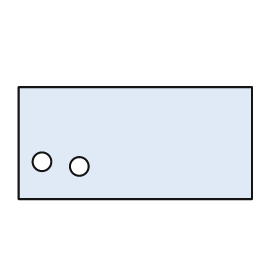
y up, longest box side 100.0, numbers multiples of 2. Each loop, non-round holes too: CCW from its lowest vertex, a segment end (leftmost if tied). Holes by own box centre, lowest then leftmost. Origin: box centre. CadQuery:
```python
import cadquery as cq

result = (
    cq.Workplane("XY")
    .moveTo(-50.0, -24.0)
    .lineTo(50.0, -24.0)
    .lineTo(50.0, 24.0)
    .lineTo(-50.0, 24.0)
    .close()
    .moveTo(-24.0, -10.0)
    .circle(4.0)
    .moveTo(-40.0, -8.0)
    .circle(4.0)
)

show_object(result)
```